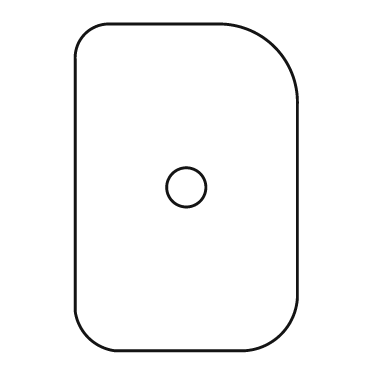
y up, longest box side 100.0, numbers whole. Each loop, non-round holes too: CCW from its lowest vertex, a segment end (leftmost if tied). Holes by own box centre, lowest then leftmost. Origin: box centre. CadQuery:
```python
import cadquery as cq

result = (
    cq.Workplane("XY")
    .moveTo(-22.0, -50.0)
    .lineTo(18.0, -50.0)
    .threePointArc((29.0, -45.0), (34.0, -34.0))
    .lineTo(34.0, 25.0)
    .threePointArc((27.0, 43.0), (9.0, 50.0))
    .lineTo(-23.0, 50.0)
    .threePointArc((-31.0, 47.0), (-34.0, 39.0))
    .lineTo(-34.0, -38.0)
    .threePointArc((-30.0, -46.0), (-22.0, -50.0))
    .close()
    .moveTo(0.0, 0.0)
    .circle(6.0)
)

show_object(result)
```